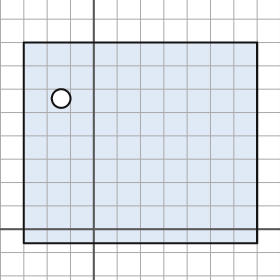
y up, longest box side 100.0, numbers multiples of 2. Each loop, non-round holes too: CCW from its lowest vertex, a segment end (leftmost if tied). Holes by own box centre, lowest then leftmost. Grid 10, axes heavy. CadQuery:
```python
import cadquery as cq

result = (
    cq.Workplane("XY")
    .moveTo(-30.0, -6.0)
    .lineTo(70.0, -6.0)
    .lineTo(70.0, 80.0)
    .lineTo(-30.0, 80.0)
    .close()
    .moveTo(-14.0, 56.0)
    .circle(4.0)
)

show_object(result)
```